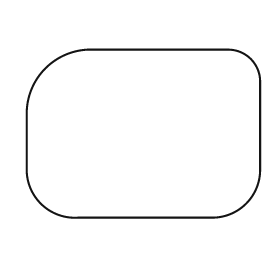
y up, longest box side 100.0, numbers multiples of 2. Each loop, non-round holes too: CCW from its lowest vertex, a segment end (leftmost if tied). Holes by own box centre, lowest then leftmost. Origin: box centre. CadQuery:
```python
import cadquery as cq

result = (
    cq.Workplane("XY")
    .moveTo(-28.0, -36.0)
    .lineTo(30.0, -36.0)
    .threePointArc((44.0, -30.0), (50.0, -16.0))
    .lineTo(50.0, 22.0)
    .threePointArc((46.0, 32.0), (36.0, 36.0))
    .lineTo(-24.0, 36.0)
    .threePointArc((-42.0, 28.0), (-50.0, 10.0))
    .lineTo(-50.0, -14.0)
    .threePointArc((-44.0, -30.0), (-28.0, -36.0))
    .close()
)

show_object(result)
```